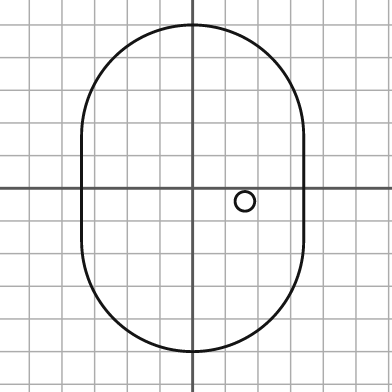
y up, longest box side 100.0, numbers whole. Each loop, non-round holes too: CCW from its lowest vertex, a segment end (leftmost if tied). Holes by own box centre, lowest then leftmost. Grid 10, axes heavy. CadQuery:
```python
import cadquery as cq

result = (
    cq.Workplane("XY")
    .moveTo(-34.0, -16.0)
    .threePointArc((0.0, -50.0), (34.0, -16.0))
    .lineTo(34.0, 16.0)
    .threePointArc((0.0, 50.0), (-34.0, 16.0))
    .close()
    .moveTo(16.0, -4.0)
    .circle(3.0)
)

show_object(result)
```